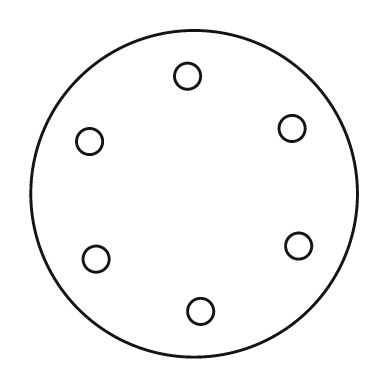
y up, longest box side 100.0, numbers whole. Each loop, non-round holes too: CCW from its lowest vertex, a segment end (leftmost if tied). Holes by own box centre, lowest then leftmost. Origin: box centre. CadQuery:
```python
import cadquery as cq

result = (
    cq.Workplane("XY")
    .moveTo(0.0, 0.0)
    .circle(50.0)
    .moveTo(2.0, -36.0)
    .circle(4.0)
    .moveTo(-30.0, -20.0)
    .circle(4.0)
    .moveTo(32.0, -16.0)
    .circle(4.0)
    .moveTo(-32.0, 16.0)
    .circle(4.0)
    .moveTo(30.0, 20.0)
    .circle(4.0)
    .moveTo(-2.0, 36.0)
    .circle(4.0)
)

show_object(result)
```